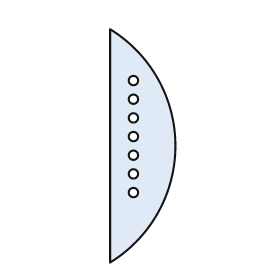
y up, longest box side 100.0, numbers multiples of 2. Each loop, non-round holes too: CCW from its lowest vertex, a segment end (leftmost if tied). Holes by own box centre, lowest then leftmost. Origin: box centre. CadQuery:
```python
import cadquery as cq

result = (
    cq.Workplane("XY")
    .moveTo(-14.0, -50.0)
    .threePointArc((14.0, 0.0), (-14.0, 50.0))
    .close()
    .moveTo(-4.0, -20.0)
    .circle(2.0)
    .moveTo(-4.0, -12.0)
    .circle(2.0)
    .moveTo(-4.0, -4.0)
    .circle(2.0)
    .moveTo(-4.0, 4.0)
    .circle(2.0)
    .moveTo(-4.0, 12.0)
    .circle(2.0)
    .moveTo(-4.0, 20.0)
    .circle(2.0)
    .moveTo(-4.0, 28.0)
    .circle(2.0)
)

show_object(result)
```